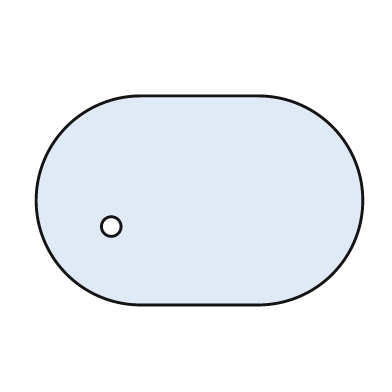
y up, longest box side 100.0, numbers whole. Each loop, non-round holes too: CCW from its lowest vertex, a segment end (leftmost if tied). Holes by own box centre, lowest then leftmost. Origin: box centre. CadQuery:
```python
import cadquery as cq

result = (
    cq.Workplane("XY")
    .moveTo(-18.0, -32.0)
    .lineTo(18.0, -32.0)
    .threePointArc((50.0, 0.0), (18.0, 32.0))
    .lineTo(-18.0, 32.0)
    .threePointArc((-50.0, 0.0), (-18.0, -32.0))
    .close()
    .moveTo(-27.0, -8.0)
    .circle(3.0)
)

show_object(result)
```